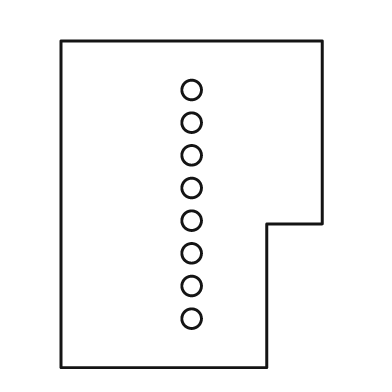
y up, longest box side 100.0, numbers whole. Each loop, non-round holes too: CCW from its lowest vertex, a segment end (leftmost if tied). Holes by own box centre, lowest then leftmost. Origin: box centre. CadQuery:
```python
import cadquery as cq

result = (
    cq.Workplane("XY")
    .moveTo(-40.0, -50.0)
    .lineTo(23.0, -50.0)
    .lineTo(23.0, -6.0)
    .lineTo(40.0, -6.0)
    .lineTo(40.0, 50.0)
    .lineTo(-40.0, 50.0)
    .close()
    .moveTo(0.0, -35.0)
    .circle(3.0)
    .moveTo(0.0, -25.0)
    .circle(3.0)
    .moveTo(0.0, -15.0)
    .circle(3.0)
    .moveTo(0.0, -5.0)
    .circle(3.0)
    .moveTo(0.0, 5.0)
    .circle(3.0)
    .moveTo(0.0, 15.0)
    .circle(3.0)
    .moveTo(0.0, 25.0)
    .circle(3.0)
    .moveTo(0.0, 35.0)
    .circle(3.0)
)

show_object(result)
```